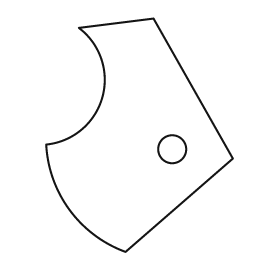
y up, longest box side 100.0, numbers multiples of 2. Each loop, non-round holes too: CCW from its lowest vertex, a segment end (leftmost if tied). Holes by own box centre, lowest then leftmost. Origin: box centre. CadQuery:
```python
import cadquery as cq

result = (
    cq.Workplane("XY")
    .moveTo(-6.0, -50.0)
    .lineTo(40.0, -10.0)
    .lineTo(6.0, 50.0)
    .lineTo(-26.0, 46.0)
    .threePointArc((-16.0, 16.0), (-40.0, -4.0))
    .threePointArc((-30.0, -32.0), (-6.0, -50.0))
    .close()
    .moveTo(14.0, -6.0)
    .circle(6.0)
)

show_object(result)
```